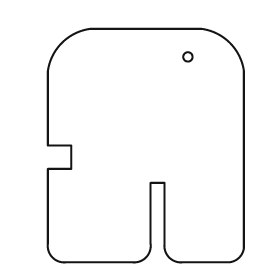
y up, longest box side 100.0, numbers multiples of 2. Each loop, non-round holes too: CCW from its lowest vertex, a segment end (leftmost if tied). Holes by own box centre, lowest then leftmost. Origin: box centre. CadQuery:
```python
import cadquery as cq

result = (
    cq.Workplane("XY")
    .moveTo(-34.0, -50.0)
    .lineTo(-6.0, -50.0)
    .threePointArc((0.0, -48.0), (2.0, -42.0))
    .lineTo(2.0, -16.0)
    .lineTo(8.0, -16.0)
    .lineTo(8.0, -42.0)
    .threePointArc((10.0, -48.0), (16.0, -50.0))
    .lineTo(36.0, -50.0)
    .threePointArc((40.0, -48.0), (42.0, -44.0))
    .lineTo(42.0, 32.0)
    .threePointArc((36.0, 44.0), (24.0, 50.0))
    .lineTo(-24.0, 50.0)
    .threePointArc((-36.0, 44.0), (-42.0, 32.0))
    .lineTo(-42.0, 0.0)
    .lineTo(-32.0, 0.0)
    .lineTo(-32.0, -10.0)
    .lineTo(-42.0, -10.0)
    .lineTo(-42.0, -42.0)
    .threePointArc((-40.0, -48.0), (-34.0, -50.0))
    .close()
    .moveTo(18.0, 38.0)
    .circle(2.0)
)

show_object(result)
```